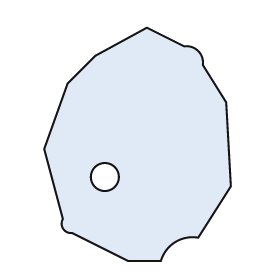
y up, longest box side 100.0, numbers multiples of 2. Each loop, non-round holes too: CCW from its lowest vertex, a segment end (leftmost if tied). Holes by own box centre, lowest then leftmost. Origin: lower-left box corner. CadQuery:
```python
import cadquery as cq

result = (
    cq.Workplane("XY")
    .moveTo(36.0, 0.0)
    .lineTo(50.0, 0.0)
    .threePointArc((56.0, 8.0), (66.0, 10.0))
    .lineTo(80.0, 32.0)
    .lineTo(78.0, 68.0)
    .lineTo(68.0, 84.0)
    .threePointArc((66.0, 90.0), (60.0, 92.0))
    .lineTo(44.0, 100.0)
    .lineTo(22.0, 88.0)
    .lineTo(10.0, 76.0)
    .lineTo(0.0, 48.0)
    .lineTo(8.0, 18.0)
    .threePointArc((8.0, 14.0), (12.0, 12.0))
    .close()
    .moveTo(26.0, 36.0)
    .circle(6.0)
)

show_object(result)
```